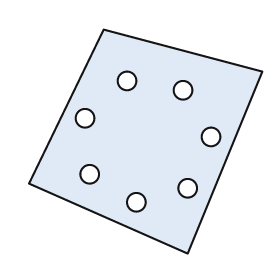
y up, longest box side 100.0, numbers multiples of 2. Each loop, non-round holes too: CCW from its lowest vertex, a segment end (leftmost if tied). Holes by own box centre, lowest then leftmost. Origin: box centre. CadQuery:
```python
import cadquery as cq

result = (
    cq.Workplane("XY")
    .moveTo(18.0, -48.0)
    .lineTo(50.0, 30.0)
    .lineTo(-18.0, 48.0)
    .lineTo(-50.0, -18.0)
    .close()
    .moveTo(-4.0, -26.0)
    .circle(4.0)
    .moveTo(18.0, -20.0)
    .circle(4.0)
    .moveTo(-24.0, -14.0)
    .circle(4.0)
    .moveTo(28.0, 2.0)
    .circle(4.0)
    .moveTo(-26.0, 10.0)
    .circle(4.0)
    .moveTo(16.0, 22.0)
    .circle(4.0)
    .moveTo(-8.0, 26.0)
    .circle(4.0)
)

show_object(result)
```